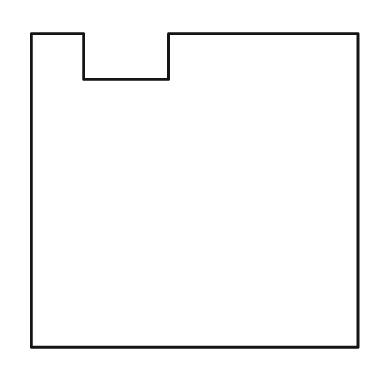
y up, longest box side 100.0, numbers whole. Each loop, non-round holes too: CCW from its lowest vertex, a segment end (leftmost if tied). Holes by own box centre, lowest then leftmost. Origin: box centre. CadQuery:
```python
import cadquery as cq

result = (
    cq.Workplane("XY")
    .moveTo(-50.0, -48.0)
    .lineTo(50.0, -48.0)
    .lineTo(50.0, 48.0)
    .lineTo(-8.0, 48.0)
    .lineTo(-8.0, 34.0)
    .lineTo(-34.0, 34.0)
    .lineTo(-34.0, 48.0)
    .lineTo(-50.0, 48.0)
    .close()
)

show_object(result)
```